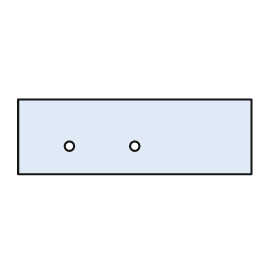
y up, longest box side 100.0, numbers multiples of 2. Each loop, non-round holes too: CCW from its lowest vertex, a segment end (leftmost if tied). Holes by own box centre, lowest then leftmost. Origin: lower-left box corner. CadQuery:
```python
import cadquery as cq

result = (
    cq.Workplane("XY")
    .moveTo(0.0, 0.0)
    .lineTo(100.0, 0.0)
    .lineTo(100.0, 32.0)
    .lineTo(0.0, 32.0)
    .close()
    .moveTo(22.0, 12.0)
    .circle(2.0)
    .moveTo(50.0, 12.0)
    .circle(2.0)
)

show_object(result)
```